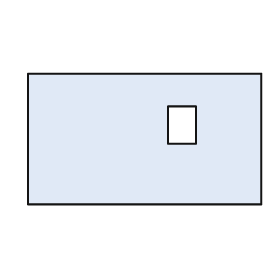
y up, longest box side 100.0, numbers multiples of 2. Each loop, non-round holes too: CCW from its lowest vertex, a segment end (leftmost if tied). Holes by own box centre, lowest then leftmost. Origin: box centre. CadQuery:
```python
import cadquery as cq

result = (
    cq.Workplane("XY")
    .moveTo(-50.0, -28.0)
    .lineTo(50.0, -28.0)
    .lineTo(50.0, 28.0)
    .lineTo(-50.0, 28.0)
    .close()
    .moveTo(10.0, -2.0)
    .lineTo(22.0, -2.0)
    .lineTo(22.0, 14.0)
    .lineTo(10.0, 14.0)
    .close()
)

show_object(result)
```